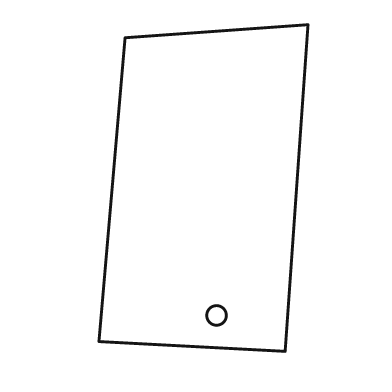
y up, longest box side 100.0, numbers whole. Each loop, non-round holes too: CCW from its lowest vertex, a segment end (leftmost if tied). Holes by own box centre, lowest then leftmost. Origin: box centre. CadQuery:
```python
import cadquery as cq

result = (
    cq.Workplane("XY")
    .moveTo(25.0, -50.0)
    .lineTo(32.0, 50.0)
    .lineTo(-24.0, 46.0)
    .lineTo(-32.0, -47.0)
    .close()
    .moveTo(4.0, -39.0)
    .circle(3.0)
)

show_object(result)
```